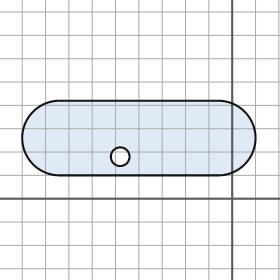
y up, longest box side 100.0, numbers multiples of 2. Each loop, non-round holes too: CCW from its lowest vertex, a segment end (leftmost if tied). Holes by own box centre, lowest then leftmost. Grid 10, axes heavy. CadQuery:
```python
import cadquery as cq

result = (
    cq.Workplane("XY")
    .moveTo(-74.0, 10.0)
    .lineTo(-6.0, 10.0)
    .threePointArc((10.0, 26.0), (-6.0, 42.0))
    .lineTo(-74.0, 42.0)
    .threePointArc((-90.0, 26.0), (-74.0, 10.0))
    .close()
    .moveTo(-48.0, 18.0)
    .circle(4.0)
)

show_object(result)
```